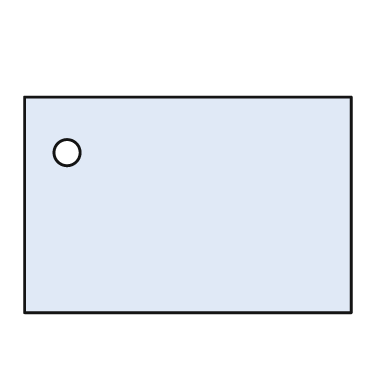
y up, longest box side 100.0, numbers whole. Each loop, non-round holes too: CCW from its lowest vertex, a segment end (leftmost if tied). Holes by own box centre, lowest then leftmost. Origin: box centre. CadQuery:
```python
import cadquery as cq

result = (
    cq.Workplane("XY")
    .moveTo(-50.0, -33.0)
    .lineTo(50.0, -33.0)
    .lineTo(50.0, 33.0)
    .lineTo(-50.0, 33.0)
    .close()
    .moveTo(-37.0, 16.0)
    .circle(4.0)
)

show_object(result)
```